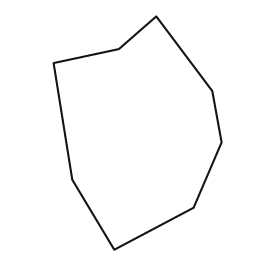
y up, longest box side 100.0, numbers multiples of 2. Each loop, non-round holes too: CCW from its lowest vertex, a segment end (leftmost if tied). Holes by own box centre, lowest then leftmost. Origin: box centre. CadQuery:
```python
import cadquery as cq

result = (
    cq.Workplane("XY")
    .moveTo(-10.0, -50.0)
    .lineTo(24.0, -32.0)
    .lineTo(36.0, -4.0)
    .lineTo(32.0, 18.0)
    .lineTo(8.0, 50.0)
    .lineTo(-8.0, 36.0)
    .lineTo(-36.0, 30.0)
    .lineTo(-28.0, -20.0)
    .close()
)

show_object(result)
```